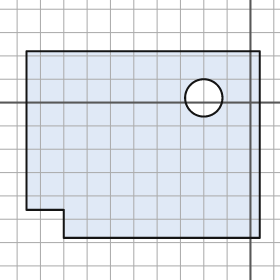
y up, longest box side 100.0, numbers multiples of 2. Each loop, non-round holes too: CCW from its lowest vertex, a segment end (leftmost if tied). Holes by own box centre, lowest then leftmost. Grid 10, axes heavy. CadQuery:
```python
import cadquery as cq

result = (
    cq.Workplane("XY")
    .moveTo(-80.0, -58.0)
    .lineTo(4.0, -58.0)
    .lineTo(4.0, 22.0)
    .lineTo(-96.0, 22.0)
    .lineTo(-96.0, -46.0)
    .lineTo(-80.0, -46.0)
    .close()
    .moveTo(-20.0, 2.0)
    .circle(8.0)
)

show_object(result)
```